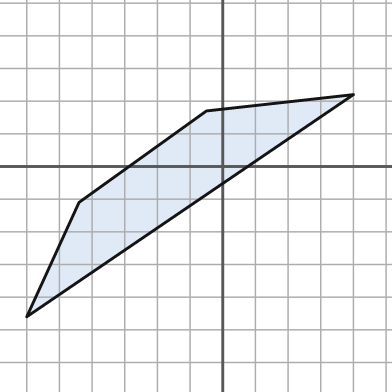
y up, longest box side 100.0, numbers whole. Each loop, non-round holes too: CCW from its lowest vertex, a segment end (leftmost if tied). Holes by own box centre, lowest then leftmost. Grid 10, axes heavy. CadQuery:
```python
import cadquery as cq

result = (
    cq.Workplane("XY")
    .moveTo(-60.0, -46.0)
    .lineTo(40.0, 22.0)
    .lineTo(-5.0, 17.0)
    .lineTo(-44.0, -11.0)
    .close()
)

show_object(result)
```